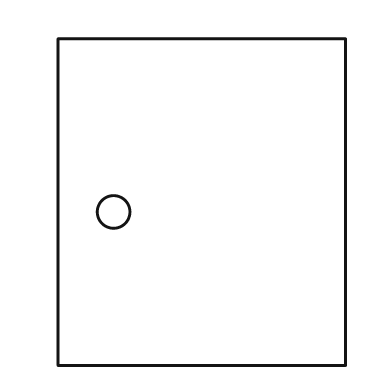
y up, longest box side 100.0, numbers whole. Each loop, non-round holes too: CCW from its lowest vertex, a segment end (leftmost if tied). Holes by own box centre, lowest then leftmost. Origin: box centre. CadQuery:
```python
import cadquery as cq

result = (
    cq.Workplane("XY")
    .moveTo(-44.0, -50.0)
    .lineTo(44.0, -50.0)
    .lineTo(44.0, 50.0)
    .lineTo(-44.0, 50.0)
    .close()
    .moveTo(-27.0, -3.0)
    .circle(5.0)
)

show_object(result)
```